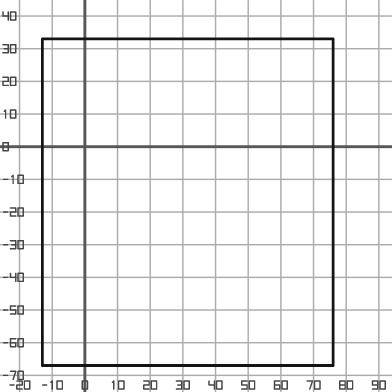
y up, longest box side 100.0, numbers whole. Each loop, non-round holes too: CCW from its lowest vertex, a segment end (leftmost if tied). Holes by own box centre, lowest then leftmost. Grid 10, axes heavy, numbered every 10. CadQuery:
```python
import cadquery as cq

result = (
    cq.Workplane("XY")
    .moveTo(-13.0, -67.0)
    .lineTo(76.0, -67.0)
    .lineTo(76.0, 33.0)
    .lineTo(-13.0, 33.0)
    .close()
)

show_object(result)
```